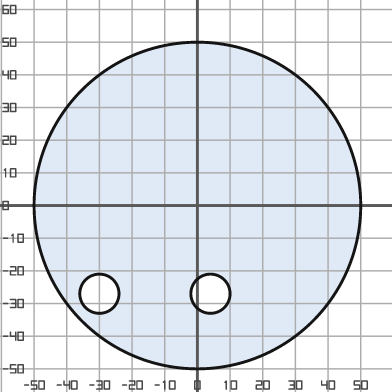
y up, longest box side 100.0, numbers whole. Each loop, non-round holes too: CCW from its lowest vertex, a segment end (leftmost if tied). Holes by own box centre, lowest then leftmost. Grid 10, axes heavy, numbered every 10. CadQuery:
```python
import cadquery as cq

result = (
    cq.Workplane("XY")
    .moveTo(0.0, 0.0)
    .circle(50.0)
    .moveTo(-30.0, -27.0)
    .circle(6.0)
    .moveTo(4.0, -27.0)
    .circle(6.0)
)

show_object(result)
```